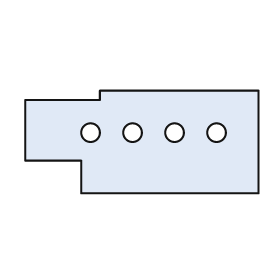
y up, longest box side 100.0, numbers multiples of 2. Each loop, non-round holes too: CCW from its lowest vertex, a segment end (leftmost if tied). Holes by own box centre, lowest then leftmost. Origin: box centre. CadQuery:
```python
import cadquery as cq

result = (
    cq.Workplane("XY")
    .moveTo(-26.0, -22.0)
    .lineTo(50.0, -22.0)
    .lineTo(50.0, 22.0)
    .lineTo(-18.0, 22.0)
    .lineTo(-18.0, 18.0)
    .lineTo(-50.0, 18.0)
    .lineTo(-50.0, -8.0)
    .lineTo(-26.0, -8.0)
    .close()
    .moveTo(-22.0, 4.0)
    .circle(4.0)
    .moveTo(-4.0, 4.0)
    .circle(4.0)
    .moveTo(14.0, 4.0)
    .circle(4.0)
    .moveTo(32.0, 4.0)
    .circle(4.0)
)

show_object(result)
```